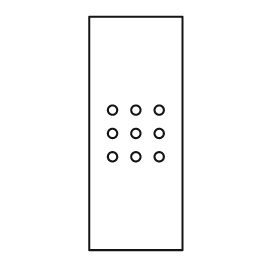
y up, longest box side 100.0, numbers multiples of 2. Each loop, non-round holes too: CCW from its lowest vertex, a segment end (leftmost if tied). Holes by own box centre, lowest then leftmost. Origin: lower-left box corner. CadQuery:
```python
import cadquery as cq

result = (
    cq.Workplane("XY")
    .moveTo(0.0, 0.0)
    .lineTo(40.0, 0.0)
    .lineTo(40.0, 100.0)
    .lineTo(0.0, 100.0)
    .close()
    .moveTo(10.0, 40.0)
    .circle(2.0)
    .moveTo(20.0, 40.0)
    .circle(2.0)
    .moveTo(30.0, 40.0)
    .circle(2.0)
    .moveTo(10.0, 50.0)
    .circle(2.0)
    .moveTo(20.0, 50.0)
    .circle(2.0)
    .moveTo(30.0, 50.0)
    .circle(2.0)
    .moveTo(10.0, 60.0)
    .circle(2.0)
    .moveTo(20.0, 60.0)
    .circle(2.0)
    .moveTo(30.0, 60.0)
    .circle(2.0)
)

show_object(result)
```